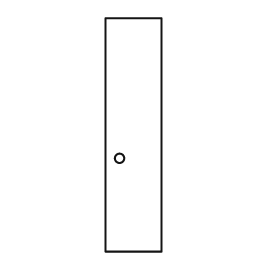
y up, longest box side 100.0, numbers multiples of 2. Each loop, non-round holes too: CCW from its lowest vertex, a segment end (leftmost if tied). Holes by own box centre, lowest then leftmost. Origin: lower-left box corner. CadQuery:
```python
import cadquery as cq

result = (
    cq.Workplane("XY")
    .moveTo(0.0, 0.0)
    .lineTo(24.0, 0.0)
    .lineTo(24.0, 100.0)
    .lineTo(0.0, 100.0)
    .close()
    .moveTo(6.0, 40.0)
    .circle(2.0)
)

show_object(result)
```